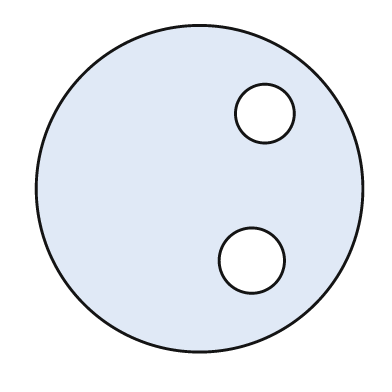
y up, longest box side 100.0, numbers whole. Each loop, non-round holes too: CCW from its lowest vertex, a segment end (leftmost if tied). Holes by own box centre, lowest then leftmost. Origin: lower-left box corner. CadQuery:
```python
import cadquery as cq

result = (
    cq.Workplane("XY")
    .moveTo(50.0, 50.0)
    .circle(50.0)
    .moveTo(66.0, 28.0)
    .circle(10.0)
    .moveTo(70.0, 73.0)
    .circle(9.0)
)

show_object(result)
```